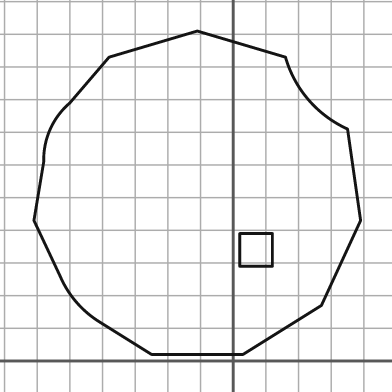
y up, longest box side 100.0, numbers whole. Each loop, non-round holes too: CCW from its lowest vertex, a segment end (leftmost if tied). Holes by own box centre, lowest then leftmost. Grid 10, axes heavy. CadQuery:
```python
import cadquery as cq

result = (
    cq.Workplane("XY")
    .moveTo(-25.0, 2.0)
    .lineTo(3.0, 2.0)
    .lineTo(27.0, 17.0)
    .lineTo(39.0, 43.0)
    .lineTo(35.0, 71.0)
    .threePointArc((23.0, 80.0), (16.0, 93.0))
    .lineTo(-11.0, 101.0)
    .lineTo(-38.0, 93.0)
    .lineTo(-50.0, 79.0)
    .threePointArc((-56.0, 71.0), (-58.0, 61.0))
    .lineTo(-61.0, 43.0)
    .lineTo(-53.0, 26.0)
    .threePointArc((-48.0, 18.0), (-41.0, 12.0))
    .close()
    .moveTo(2.0, 29.0)
    .lineTo(12.0, 29.0)
    .lineTo(12.0, 39.0)
    .lineTo(2.0, 39.0)
    .close()
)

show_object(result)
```